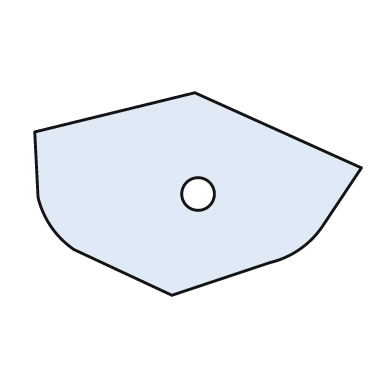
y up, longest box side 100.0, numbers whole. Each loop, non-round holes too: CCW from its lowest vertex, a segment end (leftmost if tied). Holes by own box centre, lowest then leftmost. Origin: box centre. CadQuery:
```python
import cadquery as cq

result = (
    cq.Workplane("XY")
    .moveTo(-8.0, -31.0)
    .lineTo(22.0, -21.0)
    .threePointArc((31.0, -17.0), (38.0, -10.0))
    .lineTo(50.0, 8.0)
    .lineTo(-1.0, 31.0)
    .lineTo(-50.0, 19.0)
    .lineTo(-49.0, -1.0)
    .threePointArc((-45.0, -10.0), (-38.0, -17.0))
    .close()
    .moveTo(0.0, 0.0)
    .circle(5.0)
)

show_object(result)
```